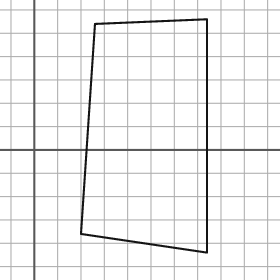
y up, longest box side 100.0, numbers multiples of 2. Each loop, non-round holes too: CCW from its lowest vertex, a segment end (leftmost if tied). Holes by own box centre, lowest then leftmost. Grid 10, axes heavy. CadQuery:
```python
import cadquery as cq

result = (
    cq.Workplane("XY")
    .moveTo(74.0, -44.0)
    .lineTo(74.0, 56.0)
    .lineTo(26.0, 54.0)
    .lineTo(20.0, -36.0)
    .close()
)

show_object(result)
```